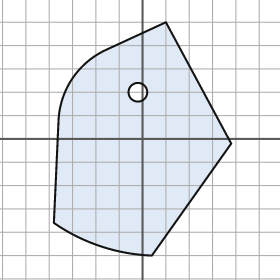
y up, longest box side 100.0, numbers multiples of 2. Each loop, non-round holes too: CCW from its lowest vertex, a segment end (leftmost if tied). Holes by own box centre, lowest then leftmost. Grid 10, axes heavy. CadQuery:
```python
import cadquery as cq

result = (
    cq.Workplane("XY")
    .moveTo(4.0, -50.0)
    .lineTo(38.0, -2.0)
    .lineTo(10.0, 50.0)
    .lineTo(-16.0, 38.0)
    .threePointArc((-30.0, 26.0), (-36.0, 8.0))
    .lineTo(-38.0, -36.0)
    .threePointArc((-18.0, -46.0), (4.0, -50.0))
    .close()
    .moveTo(-2.0, 20.0)
    .circle(4.0)
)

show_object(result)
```